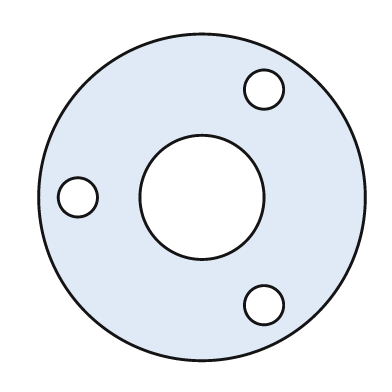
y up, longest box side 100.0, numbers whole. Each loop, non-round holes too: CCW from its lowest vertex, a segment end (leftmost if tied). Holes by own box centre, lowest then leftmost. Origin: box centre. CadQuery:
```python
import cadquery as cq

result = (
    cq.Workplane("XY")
    .moveTo(0.0, 0.0)
    .circle(50.0)
    .moveTo(19.0, -33.0)
    .circle(6.0)
    .moveTo(-38.0, 0.0)
    .circle(6.0)
    .moveTo(0.0, 0.0)
    .circle(19.0)
    .moveTo(19.0, 33.0)
    .circle(6.0)
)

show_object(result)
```